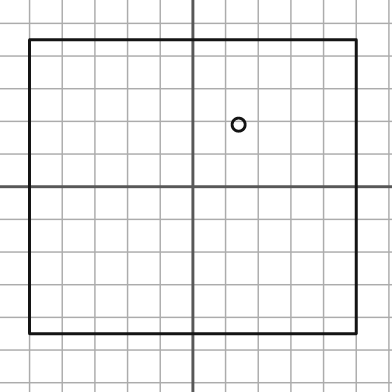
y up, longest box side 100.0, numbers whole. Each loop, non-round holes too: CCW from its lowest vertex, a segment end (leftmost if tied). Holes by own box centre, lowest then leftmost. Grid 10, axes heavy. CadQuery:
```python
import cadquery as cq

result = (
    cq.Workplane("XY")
    .moveTo(-50.0, -45.0)
    .lineTo(50.0, -45.0)
    .lineTo(50.0, 45.0)
    .lineTo(-50.0, 45.0)
    .close()
    .moveTo(14.0, 19.0)
    .circle(2.0)
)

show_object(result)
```